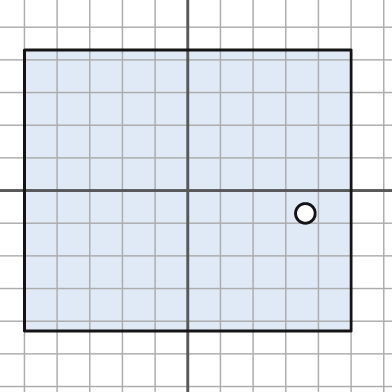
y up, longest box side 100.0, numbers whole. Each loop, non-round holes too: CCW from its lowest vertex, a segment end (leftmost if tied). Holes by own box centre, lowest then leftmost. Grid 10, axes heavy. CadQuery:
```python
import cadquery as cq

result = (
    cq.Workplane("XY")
    .moveTo(-50.0, -43.0)
    .lineTo(50.0, -43.0)
    .lineTo(50.0, 43.0)
    .lineTo(-50.0, 43.0)
    .close()
    .moveTo(36.0, -7.0)
    .circle(3.0)
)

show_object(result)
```